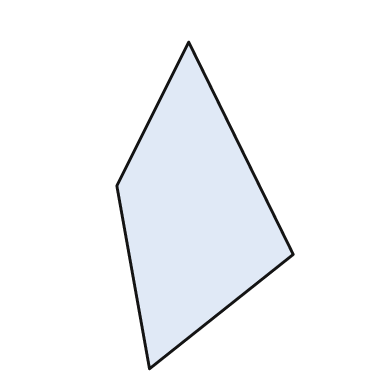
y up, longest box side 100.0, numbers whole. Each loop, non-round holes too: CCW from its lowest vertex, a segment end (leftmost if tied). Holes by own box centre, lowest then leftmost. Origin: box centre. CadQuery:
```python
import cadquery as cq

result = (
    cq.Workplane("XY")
    .moveTo(-17.0, -50.0)
    .lineTo(27.0, -15.0)
    .lineTo(-5.0, 50.0)
    .lineTo(-27.0, 6.0)
    .close()
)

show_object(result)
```